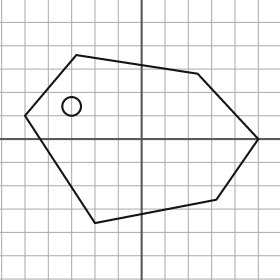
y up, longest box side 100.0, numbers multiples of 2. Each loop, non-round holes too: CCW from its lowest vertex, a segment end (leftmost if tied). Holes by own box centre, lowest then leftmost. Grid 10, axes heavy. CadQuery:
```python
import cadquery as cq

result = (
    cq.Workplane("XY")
    .moveTo(-20.0, -36.0)
    .lineTo(32.0, -26.0)
    .lineTo(50.0, 0.0)
    .lineTo(24.0, 28.0)
    .lineTo(-28.0, 36.0)
    .lineTo(-50.0, 10.0)
    .close()
    .moveTo(-30.0, 14.0)
    .circle(4.0)
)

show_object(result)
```